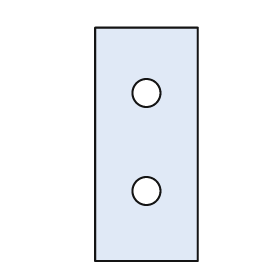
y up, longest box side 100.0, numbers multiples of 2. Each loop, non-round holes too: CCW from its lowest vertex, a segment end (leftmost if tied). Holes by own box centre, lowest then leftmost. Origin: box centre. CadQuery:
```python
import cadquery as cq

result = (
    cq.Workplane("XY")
    .moveTo(-22.0, -50.0)
    .lineTo(22.0, -50.0)
    .lineTo(22.0, 50.0)
    .lineTo(-22.0, 50.0)
    .close()
    .moveTo(0.0, -20.0)
    .circle(6.0)
    .moveTo(0.0, 22.0)
    .circle(6.0)
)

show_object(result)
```